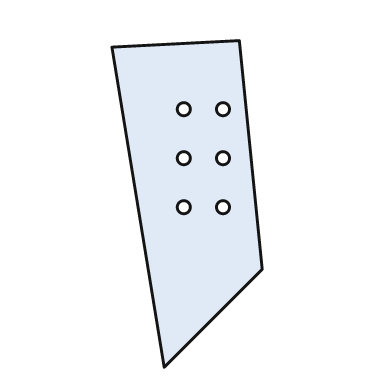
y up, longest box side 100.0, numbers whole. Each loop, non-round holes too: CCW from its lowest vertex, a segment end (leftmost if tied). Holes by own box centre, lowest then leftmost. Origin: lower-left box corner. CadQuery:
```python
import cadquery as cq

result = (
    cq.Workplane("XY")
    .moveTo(16.0, 0.0)
    .lineTo(46.0, 30.0)
    .lineTo(39.0, 100.0)
    .lineTo(0.0, 98.0)
    .close()
    .moveTo(22.0, 49.0)
    .circle(2.0)
    .moveTo(34.0, 49.0)
    .circle(2.0)
    .moveTo(22.0, 64.0)
    .circle(2.0)
    .moveTo(34.0, 64.0)
    .circle(2.0)
    .moveTo(22.0, 79.0)
    .circle(2.0)
    .moveTo(34.0, 79.0)
    .circle(2.0)
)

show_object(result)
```